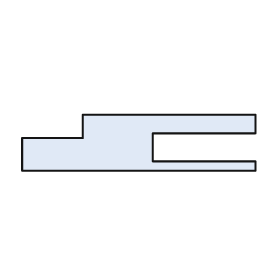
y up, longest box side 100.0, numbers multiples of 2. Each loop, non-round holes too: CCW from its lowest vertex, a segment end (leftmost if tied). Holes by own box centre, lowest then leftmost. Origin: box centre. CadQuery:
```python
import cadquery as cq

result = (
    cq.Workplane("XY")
    .moveTo(-50.0, -12.0)
    .lineTo(50.0, -12.0)
    .lineTo(50.0, -8.0)
    .lineTo(6.0, -8.0)
    .lineTo(6.0, 4.0)
    .lineTo(50.0, 4.0)
    .lineTo(50.0, 12.0)
    .lineTo(-24.0, 12.0)
    .lineTo(-24.0, 2.0)
    .lineTo(-50.0, 2.0)
    .close()
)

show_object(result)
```